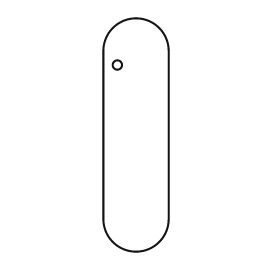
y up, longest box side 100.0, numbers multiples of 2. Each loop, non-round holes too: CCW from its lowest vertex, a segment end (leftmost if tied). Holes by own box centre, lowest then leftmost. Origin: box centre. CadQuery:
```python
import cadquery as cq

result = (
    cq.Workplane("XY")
    .moveTo(-14.0, -36.0)
    .threePointArc((0.0, -50.0), (14.0, -36.0))
    .lineTo(14.0, 36.0)
    .threePointArc((0.0, 50.0), (-14.0, 36.0))
    .close()
    .moveTo(-8.0, 30.0)
    .circle(2.0)
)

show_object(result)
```